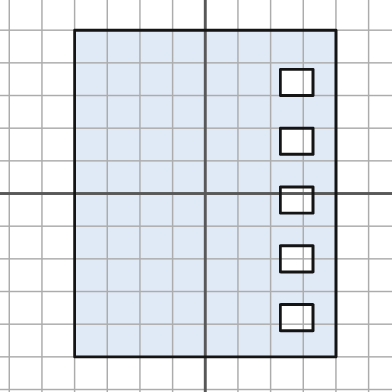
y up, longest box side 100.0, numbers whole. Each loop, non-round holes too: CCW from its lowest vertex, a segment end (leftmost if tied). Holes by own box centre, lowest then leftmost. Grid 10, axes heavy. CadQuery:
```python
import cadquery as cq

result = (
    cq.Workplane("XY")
    .moveTo(-40.0, -50.0)
    .lineTo(40.0, -50.0)
    .lineTo(40.0, 50.0)
    .lineTo(-40.0, 50.0)
    .close()
    .moveTo(23.0, -42.0)
    .lineTo(33.0, -42.0)
    .lineTo(33.0, -34.0)
    .lineTo(23.0, -34.0)
    .close()
    .moveTo(23.0, -24.0)
    .lineTo(33.0, -24.0)
    .lineTo(33.0, -16.0)
    .lineTo(23.0, -16.0)
    .close()
    .moveTo(23.0, -6.0)
    .lineTo(33.0, -6.0)
    .lineTo(33.0, 2.0)
    .lineTo(23.0, 2.0)
    .close()
    .moveTo(23.0, 12.0)
    .lineTo(33.0, 12.0)
    .lineTo(33.0, 20.0)
    .lineTo(23.0, 20.0)
    .close()
    .moveTo(23.0, 30.0)
    .lineTo(33.0, 30.0)
    .lineTo(33.0, 38.0)
    .lineTo(23.0, 38.0)
    .close()
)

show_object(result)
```